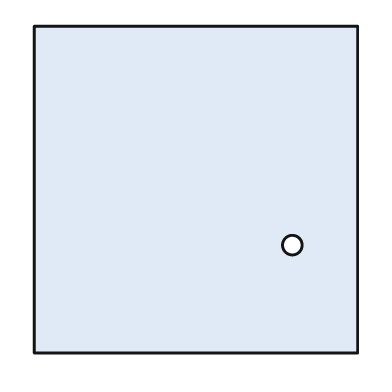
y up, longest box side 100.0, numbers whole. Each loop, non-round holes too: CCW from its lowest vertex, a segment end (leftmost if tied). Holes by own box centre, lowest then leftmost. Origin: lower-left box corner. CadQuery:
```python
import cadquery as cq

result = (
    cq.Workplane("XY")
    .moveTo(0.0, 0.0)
    .lineTo(99.0, 0.0)
    .lineTo(99.0, 100.0)
    .lineTo(0.0, 100.0)
    .close()
    .moveTo(79.0, 33.0)
    .circle(3.0)
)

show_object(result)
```